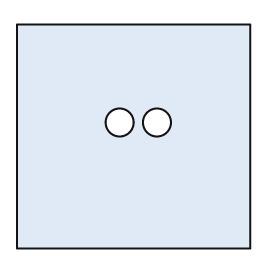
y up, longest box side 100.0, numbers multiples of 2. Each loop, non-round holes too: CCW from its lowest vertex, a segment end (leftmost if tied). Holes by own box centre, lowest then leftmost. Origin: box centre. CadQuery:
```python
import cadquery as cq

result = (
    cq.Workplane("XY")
    .moveTo(-50.0, -48.0)
    .lineTo(50.0, -48.0)
    .lineTo(50.0, 48.0)
    .lineTo(-50.0, 48.0)
    .close()
    .moveTo(-6.0, 6.0)
    .circle(6.0)
    .moveTo(10.0, 6.0)
    .circle(6.0)
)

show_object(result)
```